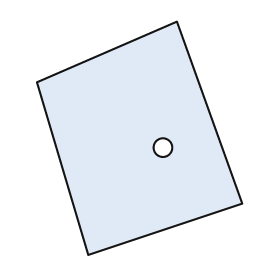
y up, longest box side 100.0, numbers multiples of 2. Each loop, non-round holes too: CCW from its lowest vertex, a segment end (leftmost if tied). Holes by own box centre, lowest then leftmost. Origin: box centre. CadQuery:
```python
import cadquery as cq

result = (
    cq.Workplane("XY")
    .moveTo(-22.0, -50.0)
    .lineTo(44.0, -28.0)
    .lineTo(16.0, 50.0)
    .lineTo(-44.0, 24.0)
    .close()
    .moveTo(10.0, -4.0)
    .circle(4.0)
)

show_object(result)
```